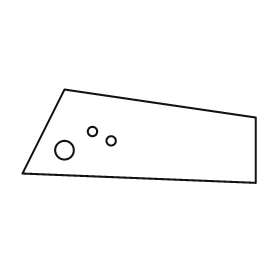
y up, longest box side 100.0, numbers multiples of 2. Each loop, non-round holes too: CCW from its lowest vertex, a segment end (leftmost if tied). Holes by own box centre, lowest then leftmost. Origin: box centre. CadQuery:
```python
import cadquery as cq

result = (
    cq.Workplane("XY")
    .moveTo(50.0, -20.0)
    .lineTo(50.0, 8.0)
    .lineTo(-32.0, 20.0)
    .lineTo(-50.0, -16.0)
    .close()
    .moveTo(-32.0, -6.0)
    .circle(4.0)
    .moveTo(-12.0, -2.0)
    .circle(2.0)
    .moveTo(-20.0, 2.0)
    .circle(2.0)
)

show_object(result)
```